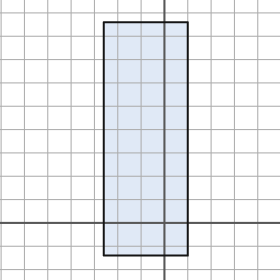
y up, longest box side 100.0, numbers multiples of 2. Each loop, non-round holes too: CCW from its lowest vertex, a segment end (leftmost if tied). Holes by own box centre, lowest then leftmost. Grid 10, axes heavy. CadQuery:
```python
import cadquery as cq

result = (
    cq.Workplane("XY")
    .moveTo(-26.0, -14.0)
    .lineTo(10.0, -14.0)
    .lineTo(10.0, 86.0)
    .lineTo(-26.0, 86.0)
    .close()
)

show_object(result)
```